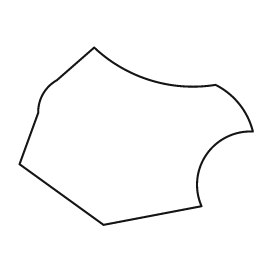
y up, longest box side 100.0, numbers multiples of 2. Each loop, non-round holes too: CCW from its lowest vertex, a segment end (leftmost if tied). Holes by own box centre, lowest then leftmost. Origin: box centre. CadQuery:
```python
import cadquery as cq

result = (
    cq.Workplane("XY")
    .moveTo(-14.0, -38.0)
    .lineTo(28.0, -30.0)
    .threePointArc((30.0, -8.0), (50.0, 2.0))
    .threePointArc((44.0, 14.0), (34.0, 22.0))
    .threePointArc((6.0, 24.0), (-18.0, 38.0))
    .lineTo(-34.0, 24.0)
    .threePointArc((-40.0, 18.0), (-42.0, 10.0))
    .lineTo(-50.0, -12.0)
    .close()
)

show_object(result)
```